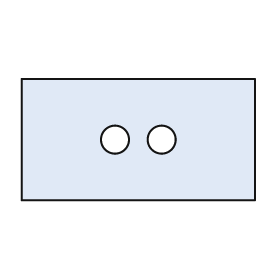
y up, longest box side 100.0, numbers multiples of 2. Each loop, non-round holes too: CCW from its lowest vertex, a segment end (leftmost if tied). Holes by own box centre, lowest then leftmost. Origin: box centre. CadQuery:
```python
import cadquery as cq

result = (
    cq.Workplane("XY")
    .moveTo(-50.0, -26.0)
    .lineTo(50.0, -26.0)
    .lineTo(50.0, 26.0)
    .lineTo(-50.0, 26.0)
    .close()
    .moveTo(-10.0, 0.0)
    .circle(6.0)
    .moveTo(10.0, 0.0)
    .circle(6.0)
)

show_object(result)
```